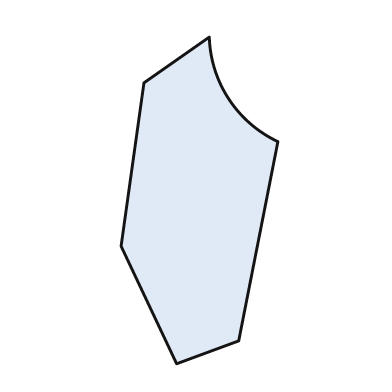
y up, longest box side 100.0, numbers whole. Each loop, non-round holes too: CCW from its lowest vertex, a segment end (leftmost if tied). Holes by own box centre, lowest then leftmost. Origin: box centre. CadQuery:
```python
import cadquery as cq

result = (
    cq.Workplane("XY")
    .moveTo(-7.0, -50.0)
    .lineTo(12.0, -43.0)
    .lineTo(24.0, 18.0)
    .threePointArc((9.0, 31.0), (3.0, 50.0))
    .lineTo(-17.0, 36.0)
    .lineTo(-24.0, -14.0)
    .close()
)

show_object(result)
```